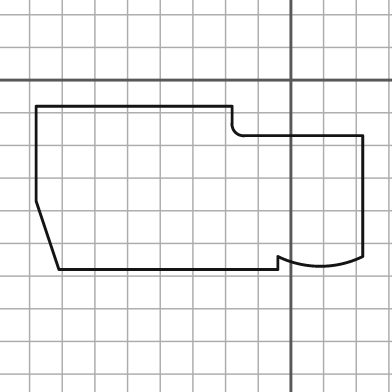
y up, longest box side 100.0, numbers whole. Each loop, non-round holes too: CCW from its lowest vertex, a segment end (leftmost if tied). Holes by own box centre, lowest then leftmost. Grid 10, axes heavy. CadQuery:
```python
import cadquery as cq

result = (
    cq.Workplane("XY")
    .moveTo(-71.0, -58.0)
    .lineTo(-4.0, -58.0)
    .lineTo(-4.0, -54.0)
    .threePointArc((9.0, -57.0), (22.0, -54.0))
    .lineTo(22.0, -17.0)
    .lineTo(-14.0, -17.0)
    .threePointArc((-17.0, -16.0), (-18.0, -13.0))
    .lineTo(-18.0, -8.0)
    .lineTo(-78.0, -8.0)
    .lineTo(-78.0, -37.0)
    .close()
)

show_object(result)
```